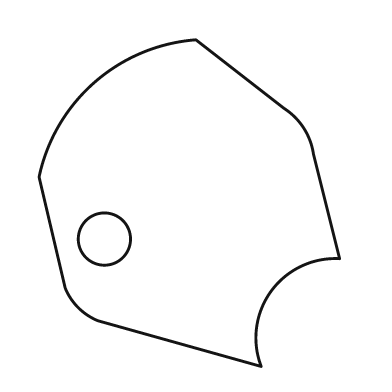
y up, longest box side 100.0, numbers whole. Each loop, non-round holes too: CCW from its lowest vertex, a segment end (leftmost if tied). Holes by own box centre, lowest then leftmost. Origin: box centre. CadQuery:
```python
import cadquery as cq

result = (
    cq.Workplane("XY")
    .moveTo(22.0, -50.0)
    .threePointArc((25.0, -27.0), (46.0, -17.0))
    .lineTo(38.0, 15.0)
    .threePointArc((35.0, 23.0), (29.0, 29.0))
    .lineTo(2.0, 50.0)
    .threePointArc((-29.0, 37.0), (-46.0, 8.0))
    .lineTo(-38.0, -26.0)
    .threePointArc((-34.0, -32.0), (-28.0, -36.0))
    .close()
    .moveTo(-26.0, -11.0)
    .circle(8.0)
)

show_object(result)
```